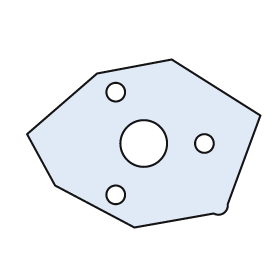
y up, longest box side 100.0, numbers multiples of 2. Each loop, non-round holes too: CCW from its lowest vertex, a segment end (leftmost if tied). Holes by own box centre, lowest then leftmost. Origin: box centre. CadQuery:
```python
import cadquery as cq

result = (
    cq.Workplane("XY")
    .moveTo(-4.0, -36.0)
    .lineTo(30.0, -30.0)
    .threePointArc((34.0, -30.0), (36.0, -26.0))
    .lineTo(50.0, 12.0)
    .lineTo(12.0, 36.0)
    .lineTo(-20.0, 30.0)
    .lineTo(-50.0, 4.0)
    .lineTo(-38.0, -18.0)
    .close()
    .moveTo(-12.0, -22.0)
    .circle(4.0)
    .moveTo(0.0, 0.0)
    .circle(10.0)
    .moveTo(26.0, 0.0)
    .circle(4.0)
    .moveTo(-12.0, 22.0)
    .circle(4.0)
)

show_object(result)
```